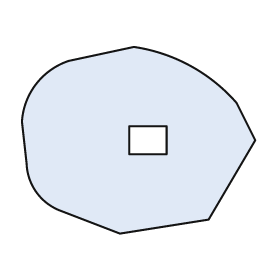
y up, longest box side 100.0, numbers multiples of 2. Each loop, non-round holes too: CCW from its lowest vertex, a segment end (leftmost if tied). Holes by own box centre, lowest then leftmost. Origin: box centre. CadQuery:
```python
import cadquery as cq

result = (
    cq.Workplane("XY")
    .moveTo(-8.0, -40.0)
    .lineTo(30.0, -34.0)
    .lineTo(50.0, 0.0)
    .lineTo(42.0, 16.0)
    .threePointArc((22.0, 32.0), (-2.0, 40.0))
    .lineTo(-30.0, 34.0)
    .threePointArc((-44.0, 24.0), (-50.0, 8.0))
    .lineTo(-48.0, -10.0)
    .threePointArc((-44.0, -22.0), (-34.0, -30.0))
    .close()
    .moveTo(-4.0, -6.0)
    .lineTo(12.0, -6.0)
    .lineTo(12.0, 6.0)
    .lineTo(-4.0, 6.0)
    .close()
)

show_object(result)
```